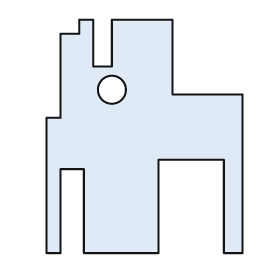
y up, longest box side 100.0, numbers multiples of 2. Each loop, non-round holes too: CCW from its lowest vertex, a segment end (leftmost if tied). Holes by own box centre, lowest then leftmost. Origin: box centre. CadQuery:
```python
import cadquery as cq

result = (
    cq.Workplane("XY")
    .moveTo(-42.0, -50.0)
    .lineTo(-36.0, -50.0)
    .lineTo(-36.0, -14.0)
    .lineTo(-26.0, -14.0)
    .lineTo(-26.0, -50.0)
    .lineTo(6.0, -50.0)
    .lineTo(6.0, -10.0)
    .lineTo(34.0, -10.0)
    .lineTo(34.0, -50.0)
    .lineTo(42.0, -50.0)
    .lineTo(42.0, 18.0)
    .lineTo(12.0, 18.0)
    .lineTo(12.0, 50.0)
    .lineTo(-14.0, 50.0)
    .lineTo(-14.0, 30.0)
    .lineTo(-22.0, 30.0)
    .lineTo(-22.0, 50.0)
    .lineTo(-28.0, 50.0)
    .lineTo(-28.0, 44.0)
    .lineTo(-36.0, 44.0)
    .lineTo(-36.0, 8.0)
    .lineTo(-42.0, 8.0)
    .close()
    .moveTo(-14.0, 20.0)
    .circle(6.0)
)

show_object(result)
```